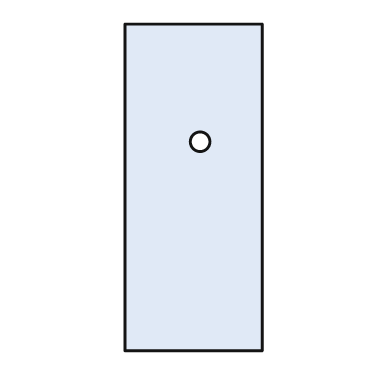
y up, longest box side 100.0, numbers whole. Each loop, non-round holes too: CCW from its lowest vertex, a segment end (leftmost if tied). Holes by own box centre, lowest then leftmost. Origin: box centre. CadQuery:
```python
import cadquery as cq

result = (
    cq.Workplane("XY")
    .moveTo(-21.0, -50.0)
    .lineTo(21.0, -50.0)
    .lineTo(21.0, 50.0)
    .lineTo(-21.0, 50.0)
    .close()
    .moveTo(2.0, 14.0)
    .circle(3.0)
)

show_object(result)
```